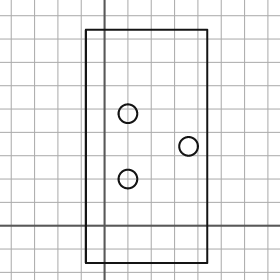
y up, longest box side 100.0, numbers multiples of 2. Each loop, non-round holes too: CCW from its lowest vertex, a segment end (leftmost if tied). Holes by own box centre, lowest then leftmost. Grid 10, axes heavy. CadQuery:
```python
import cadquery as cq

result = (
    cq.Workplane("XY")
    .moveTo(-8.0, -16.0)
    .lineTo(44.0, -16.0)
    .lineTo(44.0, 84.0)
    .lineTo(-8.0, 84.0)
    .close()
    .moveTo(10.0, 20.0)
    .circle(4.0)
    .moveTo(36.0, 34.0)
    .circle(4.0)
    .moveTo(10.0, 48.0)
    .circle(4.0)
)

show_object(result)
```